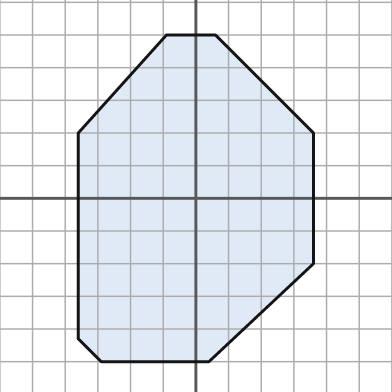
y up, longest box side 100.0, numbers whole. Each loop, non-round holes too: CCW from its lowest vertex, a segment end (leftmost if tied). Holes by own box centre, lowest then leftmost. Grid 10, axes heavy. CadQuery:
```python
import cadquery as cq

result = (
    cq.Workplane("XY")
    .moveTo(-29.0, -50.0)
    .lineTo(4.0, -50.0)
    .lineTo(36.0, -20.0)
    .lineTo(36.0, 20.0)
    .lineTo(6.0, 50.0)
    .lineTo(-9.0, 50.0)
    .lineTo(-36.0, 20.0)
    .lineTo(-36.0, -43.0)
    .close()
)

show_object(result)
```